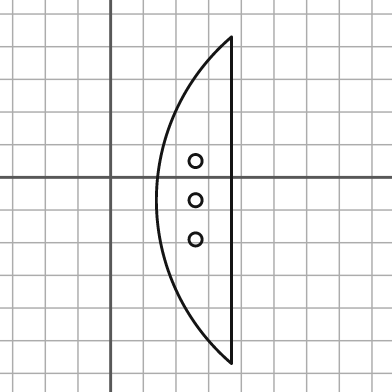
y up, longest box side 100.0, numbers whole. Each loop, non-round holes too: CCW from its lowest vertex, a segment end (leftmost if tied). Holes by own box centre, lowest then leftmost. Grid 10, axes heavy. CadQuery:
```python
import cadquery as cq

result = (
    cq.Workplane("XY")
    .moveTo(37.0, -57.0)
    .lineTo(37.0, 43.0)
    .threePointArc((14.0, -7.0), (37.0, -57.0))
    .close()
    .moveTo(26.0, -19.0)
    .circle(2.0)
    .moveTo(26.0, -7.0)
    .circle(2.0)
    .moveTo(26.0, 5.0)
    .circle(2.0)
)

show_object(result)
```